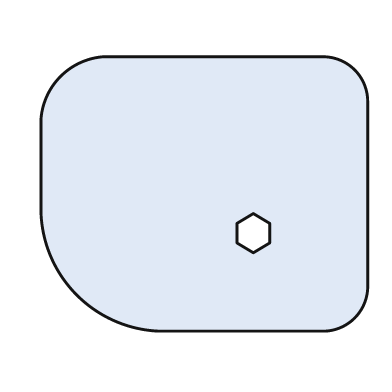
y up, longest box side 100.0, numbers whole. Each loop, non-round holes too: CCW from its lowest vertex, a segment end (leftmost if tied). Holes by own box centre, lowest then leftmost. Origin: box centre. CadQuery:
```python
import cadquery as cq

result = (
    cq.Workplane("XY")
    .moveTo(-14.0, -42.0)
    .lineTo(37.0, -42.0)
    .threePointArc((46.0, -38.0), (50.0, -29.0))
    .lineTo(50.0, 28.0)
    .threePointArc((46.0, 38.0), (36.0, 42.0))
    .lineTo(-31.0, 42.0)
    .threePointArc((-44.0, 36.0), (-50.0, 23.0))
    .lineTo(-50.0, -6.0)
    .threePointArc((-39.0, -31.0), (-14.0, -42.0))
    .close()
    .moveTo(15.0, -18.0)
    .lineTo(20.0, -15.0)
    .lineTo(20.0, -9.0)
    .lineTo(15.0, -6.0)
    .lineTo(10.0, -9.0)
    .lineTo(10.0, -15.0)
    .close()
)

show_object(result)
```